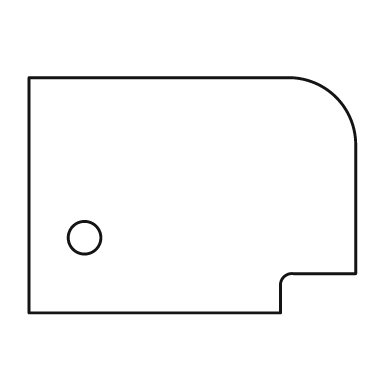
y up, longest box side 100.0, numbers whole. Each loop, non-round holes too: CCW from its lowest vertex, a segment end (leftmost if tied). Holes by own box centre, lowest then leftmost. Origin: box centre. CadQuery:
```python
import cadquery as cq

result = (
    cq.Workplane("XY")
    .moveTo(-50.0, -36.0)
    .lineTo(27.0, -36.0)
    .lineTo(27.0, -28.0)
    .threePointArc((28.0, -25.0), (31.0, -24.0))
    .lineTo(50.0, -24.0)
    .lineTo(50.0, 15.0)
    .threePointArc((44.0, 30.0), (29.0, 36.0))
    .lineTo(-50.0, 36.0)
    .close()
    .moveTo(-33.0, -13.0)
    .circle(5.0)
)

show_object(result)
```